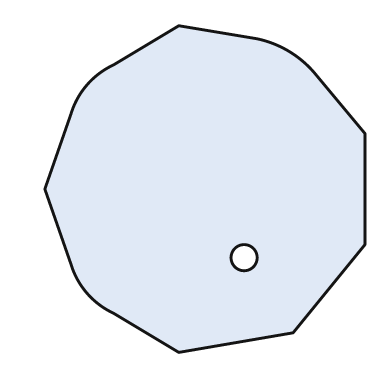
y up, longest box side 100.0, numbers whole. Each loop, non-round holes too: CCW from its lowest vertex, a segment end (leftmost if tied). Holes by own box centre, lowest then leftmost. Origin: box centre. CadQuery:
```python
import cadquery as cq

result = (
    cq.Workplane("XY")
    .moveTo(-8.0, -50.0)
    .lineTo(27.0, -44.0)
    .lineTo(49.0, -17.0)
    .lineTo(49.0, 17.0)
    .lineTo(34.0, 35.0)
    .threePointArc((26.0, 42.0), (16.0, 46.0))
    .lineTo(-8.0, 50.0)
    .lineTo(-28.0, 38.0)
    .threePointArc((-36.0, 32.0), (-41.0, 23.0))
    .lineTo(-49.0, 0.0)
    .lineTo(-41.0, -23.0)
    .threePointArc((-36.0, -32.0), (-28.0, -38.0))
    .close()
    .moveTo(12.0, -21.0)
    .circle(4.0)
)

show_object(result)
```